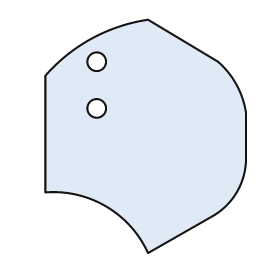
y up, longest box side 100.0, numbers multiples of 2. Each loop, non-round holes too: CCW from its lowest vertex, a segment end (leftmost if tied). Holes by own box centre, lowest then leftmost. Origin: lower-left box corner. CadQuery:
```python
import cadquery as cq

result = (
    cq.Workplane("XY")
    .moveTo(44.0, 0.0)
    .lineTo(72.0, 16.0)
    .threePointArc((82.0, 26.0), (86.0, 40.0))
    .lineTo(86.0, 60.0)
    .threePointArc((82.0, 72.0), (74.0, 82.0))
    .lineTo(44.0, 100.0)
    .threePointArc((20.0, 92.0), (0.0, 76.0))
    .lineTo(0.0, 26.0)
    .threePointArc((26.0, 20.0), (44.0, 0.0))
    .close()
    .moveTo(22.0, 62.0)
    .circle(4.0)
    .moveTo(22.0, 82.0)
    .circle(4.0)
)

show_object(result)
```